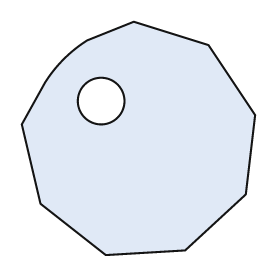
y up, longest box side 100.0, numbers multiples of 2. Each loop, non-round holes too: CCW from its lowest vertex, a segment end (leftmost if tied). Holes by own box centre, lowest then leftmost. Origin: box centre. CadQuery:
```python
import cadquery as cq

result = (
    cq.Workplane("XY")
    .moveTo(-14.0, -50.0)
    .lineTo(20.0, -48.0)
    .lineTo(46.0, -24.0)
    .lineTo(50.0, 10.0)
    .lineTo(30.0, 40.0)
    .lineTo(-2.0, 50.0)
    .lineTo(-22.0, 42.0)
    .threePointArc((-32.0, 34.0), (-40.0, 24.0))
    .lineTo(-50.0, 6.0)
    .lineTo(-42.0, -28.0)
    .close()
    .moveTo(-16.0, 16.0)
    .circle(10.0)
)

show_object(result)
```